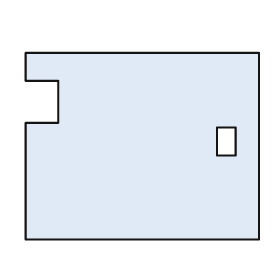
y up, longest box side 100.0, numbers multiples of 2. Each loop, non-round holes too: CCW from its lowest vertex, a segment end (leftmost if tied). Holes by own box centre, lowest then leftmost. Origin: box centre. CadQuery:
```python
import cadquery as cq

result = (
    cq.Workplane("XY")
    .moveTo(-50.0, -40.0)
    .lineTo(50.0, -40.0)
    .lineTo(50.0, 40.0)
    .lineTo(-50.0, 40.0)
    .lineTo(-50.0, 28.0)
    .lineTo(-36.0, 28.0)
    .lineTo(-36.0, 10.0)
    .lineTo(-50.0, 10.0)
    .close()
    .moveTo(32.0, -4.0)
    .lineTo(40.0, -4.0)
    .lineTo(40.0, 8.0)
    .lineTo(32.0, 8.0)
    .close()
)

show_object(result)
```